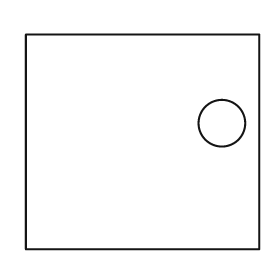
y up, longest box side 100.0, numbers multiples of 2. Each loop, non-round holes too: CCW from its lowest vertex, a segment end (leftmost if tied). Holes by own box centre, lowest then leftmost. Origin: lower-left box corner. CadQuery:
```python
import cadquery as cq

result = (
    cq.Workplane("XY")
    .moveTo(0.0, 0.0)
    .lineTo(100.0, 0.0)
    .lineTo(100.0, 92.0)
    .lineTo(0.0, 92.0)
    .close()
    .moveTo(84.0, 54.0)
    .circle(10.0)
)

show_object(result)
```